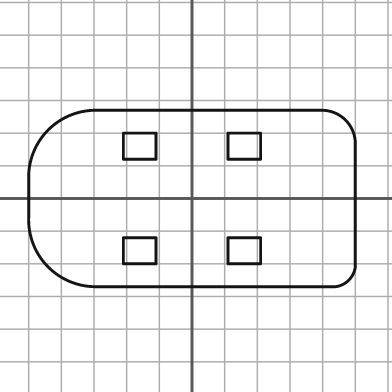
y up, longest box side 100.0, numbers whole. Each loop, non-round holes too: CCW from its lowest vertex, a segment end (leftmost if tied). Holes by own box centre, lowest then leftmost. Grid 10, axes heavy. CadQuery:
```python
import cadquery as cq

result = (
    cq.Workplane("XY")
    .moveTo(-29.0, -27.0)
    .lineTo(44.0, -27.0)
    .threePointArc((48.0, -25.0), (50.0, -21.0))
    .lineTo(50.0, 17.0)
    .threePointArc((47.0, 24.0), (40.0, 27.0))
    .lineTo(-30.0, 27.0)
    .threePointArc((-44.0, 21.0), (-50.0, 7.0))
    .lineTo(-50.0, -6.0)
    .threePointArc((-44.0, -21.0), (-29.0, -27.0))
    .close()
    .moveTo(-21.0, -20.0)
    .lineTo(-11.0, -20.0)
    .lineTo(-11.0, -12.0)
    .lineTo(-21.0, -12.0)
    .close()
    .moveTo(11.0, -20.0)
    .lineTo(21.0, -20.0)
    .lineTo(21.0, -12.0)
    .lineTo(11.0, -12.0)
    .close()
    .moveTo(-21.0, 12.0)
    .lineTo(-11.0, 12.0)
    .lineTo(-11.0, 20.0)
    .lineTo(-21.0, 20.0)
    .close()
    .moveTo(11.0, 12.0)
    .lineTo(21.0, 12.0)
    .lineTo(21.0, 20.0)
    .lineTo(11.0, 20.0)
    .close()
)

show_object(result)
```